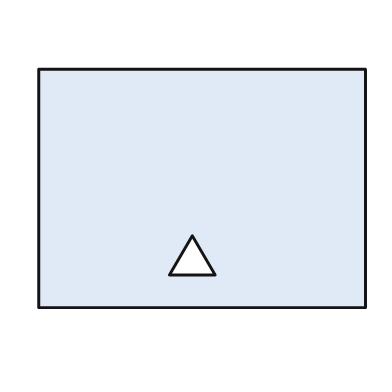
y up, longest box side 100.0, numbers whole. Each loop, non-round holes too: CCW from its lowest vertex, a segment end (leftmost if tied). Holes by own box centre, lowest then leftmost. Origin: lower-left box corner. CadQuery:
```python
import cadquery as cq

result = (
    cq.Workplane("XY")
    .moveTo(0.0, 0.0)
    .lineTo(100.0, 0.0)
    .lineTo(100.0, 73.0)
    .lineTo(0.0, 73.0)
    .close()
    .moveTo(40.0, 10.0)
    .lineTo(54.0, 10.0)
    .lineTo(47.0, 22.0)
    .close()
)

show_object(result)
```